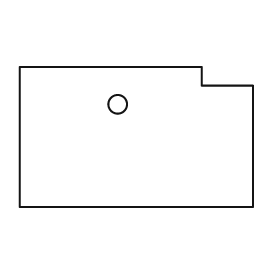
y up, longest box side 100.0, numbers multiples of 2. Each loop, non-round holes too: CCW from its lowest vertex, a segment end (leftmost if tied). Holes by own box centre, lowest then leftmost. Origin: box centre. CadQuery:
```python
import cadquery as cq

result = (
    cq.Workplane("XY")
    .moveTo(-50.0, -30.0)
    .lineTo(50.0, -30.0)
    .lineTo(50.0, 22.0)
    .lineTo(28.0, 22.0)
    .lineTo(28.0, 30.0)
    .lineTo(-50.0, 30.0)
    .close()
    .moveTo(-8.0, 14.0)
    .circle(4.0)
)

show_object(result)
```